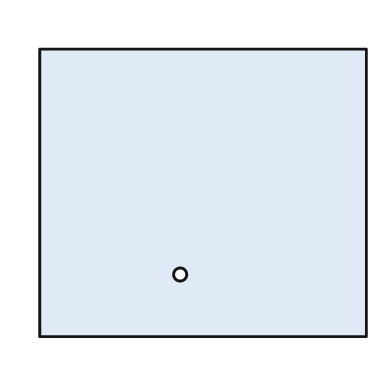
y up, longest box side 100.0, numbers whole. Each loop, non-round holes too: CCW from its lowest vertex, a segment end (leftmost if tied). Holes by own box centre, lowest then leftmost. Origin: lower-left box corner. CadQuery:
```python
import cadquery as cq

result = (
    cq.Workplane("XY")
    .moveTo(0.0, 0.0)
    .lineTo(100.0, 0.0)
    .lineTo(100.0, 88.0)
    .lineTo(0.0, 88.0)
    .close()
    .moveTo(43.0, 19.0)
    .circle(2.0)
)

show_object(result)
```